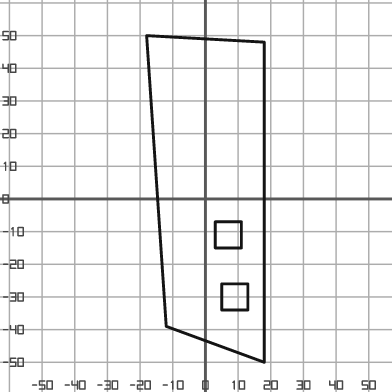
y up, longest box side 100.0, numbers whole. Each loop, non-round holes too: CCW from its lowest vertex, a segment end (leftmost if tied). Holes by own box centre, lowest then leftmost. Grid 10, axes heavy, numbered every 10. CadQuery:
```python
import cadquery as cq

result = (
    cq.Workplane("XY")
    .moveTo(18.0, -50.0)
    .lineTo(18.0, 48.0)
    .lineTo(-18.0, 50.0)
    .lineTo(-12.0, -39.0)
    .close()
    .moveTo(5.0, -34.0)
    .lineTo(13.0, -34.0)
    .lineTo(13.0, -26.0)
    .lineTo(5.0, -26.0)
    .close()
    .moveTo(3.0, -15.0)
    .lineTo(11.0, -15.0)
    .lineTo(11.0, -7.0)
    .lineTo(3.0, -7.0)
    .close()
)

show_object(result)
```